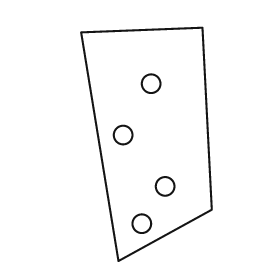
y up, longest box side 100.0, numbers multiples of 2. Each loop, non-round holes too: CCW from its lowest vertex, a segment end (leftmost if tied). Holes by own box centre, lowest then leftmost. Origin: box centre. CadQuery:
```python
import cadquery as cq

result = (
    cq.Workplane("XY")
    .moveTo(-12.0, -50.0)
    .lineTo(28.0, -28.0)
    .lineTo(24.0, 50.0)
    .lineTo(-28.0, 48.0)
    .close()
    .moveTo(-2.0, -34.0)
    .circle(4.0)
    .moveTo(8.0, -18.0)
    .circle(4.0)
    .moveTo(-10.0, 4.0)
    .circle(4.0)
    .moveTo(2.0, 26.0)
    .circle(4.0)
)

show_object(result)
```